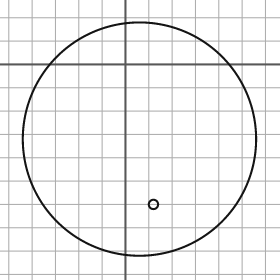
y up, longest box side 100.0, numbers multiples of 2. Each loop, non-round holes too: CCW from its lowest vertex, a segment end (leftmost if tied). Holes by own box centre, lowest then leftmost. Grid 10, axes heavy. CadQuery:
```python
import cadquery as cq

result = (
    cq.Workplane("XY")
    .moveTo(6.0, -32.0)
    .circle(50.0)
    .moveTo(12.0, -60.0)
    .circle(2.0)
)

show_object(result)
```